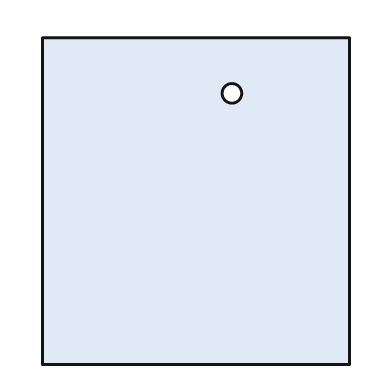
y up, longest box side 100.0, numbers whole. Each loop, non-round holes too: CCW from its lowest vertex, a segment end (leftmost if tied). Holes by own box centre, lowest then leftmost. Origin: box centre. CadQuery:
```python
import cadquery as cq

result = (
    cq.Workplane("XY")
    .moveTo(-47.0, -50.0)
    .lineTo(47.0, -50.0)
    .lineTo(47.0, 50.0)
    .lineTo(-47.0, 50.0)
    .close()
    .moveTo(11.0, 33.0)
    .circle(3.0)
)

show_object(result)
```